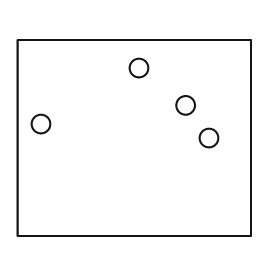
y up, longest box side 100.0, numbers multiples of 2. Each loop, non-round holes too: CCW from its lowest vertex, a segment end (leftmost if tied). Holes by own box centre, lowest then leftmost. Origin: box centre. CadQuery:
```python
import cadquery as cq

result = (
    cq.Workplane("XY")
    .moveTo(-50.0, -42.0)
    .lineTo(50.0, -42.0)
    .lineTo(50.0, 42.0)
    .lineTo(-50.0, 42.0)
    .close()
    .moveTo(32.0, 0.0)
    .circle(4.0)
    .moveTo(-40.0, 6.0)
    .circle(4.0)
    .moveTo(22.0, 14.0)
    .circle(4.0)
    .moveTo(2.0, 30.0)
    .circle(4.0)
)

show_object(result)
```